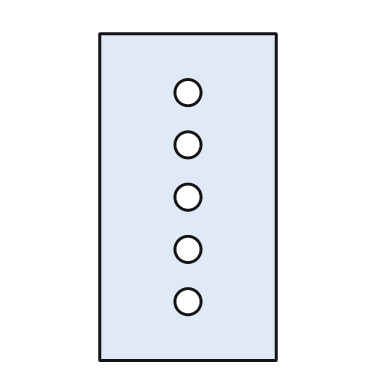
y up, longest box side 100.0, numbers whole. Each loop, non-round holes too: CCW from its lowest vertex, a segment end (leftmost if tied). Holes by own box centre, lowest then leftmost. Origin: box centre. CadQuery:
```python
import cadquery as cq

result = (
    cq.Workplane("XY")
    .moveTo(-27.0, -50.0)
    .lineTo(27.0, -50.0)
    .lineTo(27.0, 50.0)
    .lineTo(-27.0, 50.0)
    .close()
    .moveTo(0.0, -32.0)
    .circle(4.0)
    .moveTo(0.0, -16.0)
    .circle(4.0)
    .moveTo(0.0, 0.0)
    .circle(4.0)
    .moveTo(0.0, 16.0)
    .circle(4.0)
    .moveTo(0.0, 32.0)
    .circle(4.0)
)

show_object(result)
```